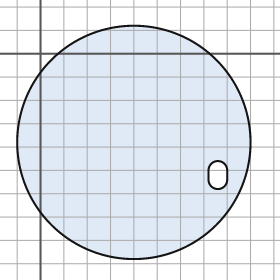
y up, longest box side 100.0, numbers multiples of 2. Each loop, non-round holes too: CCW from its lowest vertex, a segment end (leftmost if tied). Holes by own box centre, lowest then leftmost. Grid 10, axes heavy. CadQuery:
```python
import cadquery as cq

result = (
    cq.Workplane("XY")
    .moveTo(40.0, -38.0)
    .circle(50.0)
    .moveTo(72.0, -54.0)
    .threePointArc((76.0, -58.0), (80.0, -54.0))
    .lineTo(80.0, -50.0)
    .threePointArc((76.0, -46.0), (72.0, -50.0))
    .close()
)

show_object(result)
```